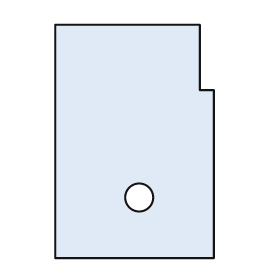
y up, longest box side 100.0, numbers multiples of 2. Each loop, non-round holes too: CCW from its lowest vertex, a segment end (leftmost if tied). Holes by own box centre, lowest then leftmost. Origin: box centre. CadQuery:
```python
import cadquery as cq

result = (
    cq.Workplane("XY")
    .moveTo(-34.0, -50.0)
    .lineTo(34.0, -50.0)
    .lineTo(34.0, 22.0)
    .lineTo(28.0, 22.0)
    .lineTo(28.0, 50.0)
    .lineTo(-34.0, 50.0)
    .close()
    .moveTo(2.0, -24.0)
    .circle(6.0)
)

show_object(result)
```